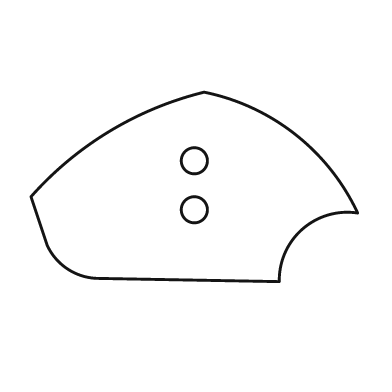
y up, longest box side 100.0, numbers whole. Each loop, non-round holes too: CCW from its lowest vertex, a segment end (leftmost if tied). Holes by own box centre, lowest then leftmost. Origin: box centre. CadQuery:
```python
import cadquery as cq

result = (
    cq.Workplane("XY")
    .moveTo(26.0, -29.0)
    .threePointArc((33.0, -13.0), (50.0, -8.0))
    .threePointArc((31.0, 16.0), (3.0, 29.0))
    .threePointArc((-26.0, 17.0), (-50.0, -3.0))
    .lineTo(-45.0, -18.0)
    .threePointArc((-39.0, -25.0), (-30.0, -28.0))
    .close()
    .moveTo(0.0, -7.0)
    .circle(4.0)
    .moveTo(0.0, 8.0)
    .circle(4.0)
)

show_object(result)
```